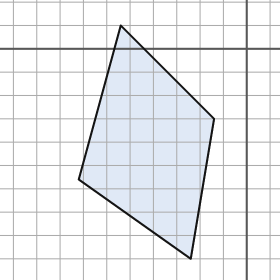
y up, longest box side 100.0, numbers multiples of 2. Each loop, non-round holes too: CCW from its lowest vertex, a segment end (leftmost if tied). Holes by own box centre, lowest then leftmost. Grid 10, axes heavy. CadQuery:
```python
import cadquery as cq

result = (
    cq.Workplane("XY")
    .moveTo(-24.0, -90.0)
    .lineTo(-14.0, -30.0)
    .lineTo(-54.0, 10.0)
    .lineTo(-72.0, -56.0)
    .close()
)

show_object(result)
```